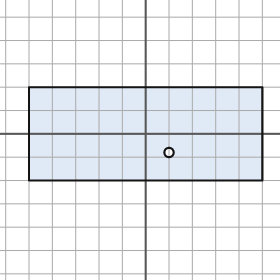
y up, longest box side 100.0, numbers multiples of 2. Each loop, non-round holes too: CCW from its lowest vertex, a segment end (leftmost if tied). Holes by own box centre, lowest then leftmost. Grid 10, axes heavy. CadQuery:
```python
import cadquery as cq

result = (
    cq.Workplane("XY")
    .moveTo(-50.0, -20.0)
    .lineTo(50.0, -20.0)
    .lineTo(50.0, 20.0)
    .lineTo(-50.0, 20.0)
    .close()
    .moveTo(10.0, -8.0)
    .circle(2.0)
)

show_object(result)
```